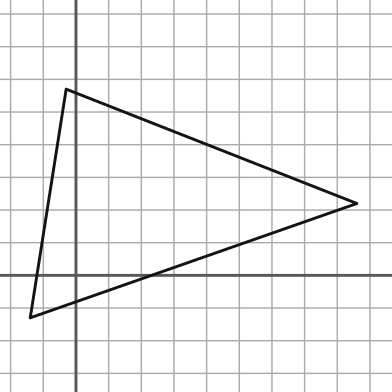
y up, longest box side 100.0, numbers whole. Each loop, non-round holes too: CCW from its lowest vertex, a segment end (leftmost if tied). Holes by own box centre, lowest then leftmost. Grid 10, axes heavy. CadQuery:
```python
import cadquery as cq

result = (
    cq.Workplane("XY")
    .moveTo(-14.0, -13.0)
    .lineTo(86.0, 22.0)
    .lineTo(-3.0, 57.0)
    .close()
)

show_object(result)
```